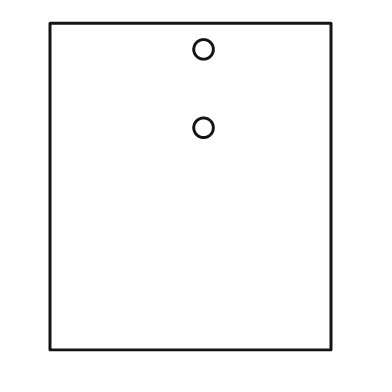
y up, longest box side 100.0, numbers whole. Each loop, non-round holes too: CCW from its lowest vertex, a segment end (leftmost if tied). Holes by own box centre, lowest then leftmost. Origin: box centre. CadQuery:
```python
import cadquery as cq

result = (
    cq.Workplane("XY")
    .moveTo(-43.0, -50.0)
    .lineTo(43.0, -50.0)
    .lineTo(43.0, 50.0)
    .lineTo(-43.0, 50.0)
    .close()
    .moveTo(4.0, 18.0)
    .circle(3.0)
    .moveTo(4.0, 42.0)
    .circle(3.0)
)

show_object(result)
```